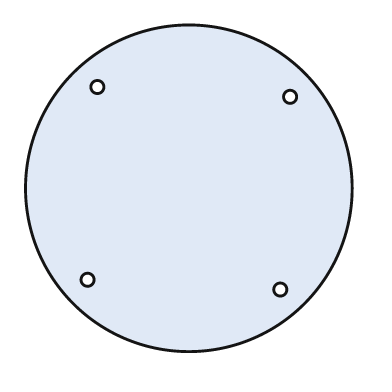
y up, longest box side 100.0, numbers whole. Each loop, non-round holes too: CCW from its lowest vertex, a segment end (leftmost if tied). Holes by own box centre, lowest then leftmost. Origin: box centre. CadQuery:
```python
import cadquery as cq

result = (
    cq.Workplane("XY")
    .moveTo(0.0, 0.0)
    .circle(50.0)
    .moveTo(28.0, -31.0)
    .circle(2.0)
    .moveTo(-31.0, -28.0)
    .circle(2.0)
    .moveTo(31.0, 28.0)
    .circle(2.0)
    .moveTo(-28.0, 31.0)
    .circle(2.0)
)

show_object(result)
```